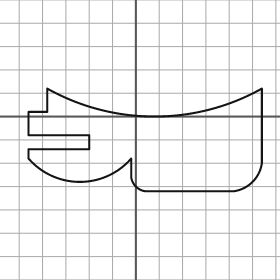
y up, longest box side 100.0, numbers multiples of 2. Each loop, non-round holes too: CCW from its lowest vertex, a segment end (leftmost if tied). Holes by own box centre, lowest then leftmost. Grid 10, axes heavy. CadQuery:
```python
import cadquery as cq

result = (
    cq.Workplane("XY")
    .moveTo(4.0, -32.0)
    .lineTo(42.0, -32.0)
    .threePointArc((50.0, -28.0), (54.0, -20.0))
    .lineTo(54.0, 12.0)
    .threePointArc((8.0, 0.0), (-38.0, 12.0))
    .lineTo(-38.0, 2.0)
    .lineTo(-46.0, 2.0)
    .lineTo(-46.0, -8.0)
    .lineTo(-20.0, -8.0)
    .lineTo(-20.0, -14.0)
    .lineTo(-46.0, -14.0)
    .lineTo(-46.0, -18.0)
    .threePointArc((-24.0, -28.0), (-2.0, -18.0))
    .lineTo(-2.0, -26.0)
    .threePointArc((0.0, -30.0), (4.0, -32.0))
    .close()
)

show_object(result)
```